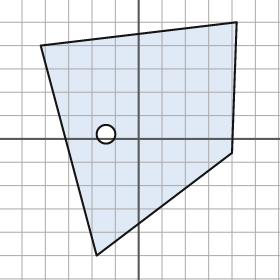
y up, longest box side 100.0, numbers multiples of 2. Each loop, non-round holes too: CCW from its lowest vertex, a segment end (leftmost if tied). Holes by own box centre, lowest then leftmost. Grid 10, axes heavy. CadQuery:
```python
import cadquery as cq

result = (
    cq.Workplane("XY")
    .moveTo(-18.0, -50.0)
    .lineTo(40.0, -6.0)
    .lineTo(42.0, 50.0)
    .lineTo(-42.0, 40.0)
    .close()
    .moveTo(-14.0, 2.0)
    .circle(4.0)
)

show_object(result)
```